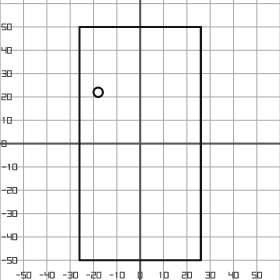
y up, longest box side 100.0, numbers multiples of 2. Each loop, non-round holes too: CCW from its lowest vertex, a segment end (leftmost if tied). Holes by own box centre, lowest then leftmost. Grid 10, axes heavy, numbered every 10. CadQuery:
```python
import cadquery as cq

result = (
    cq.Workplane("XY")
    .moveTo(-26.0, -50.0)
    .lineTo(26.0, -50.0)
    .lineTo(26.0, 50.0)
    .lineTo(-26.0, 50.0)
    .close()
    .moveTo(-18.0, 22.0)
    .circle(2.0)
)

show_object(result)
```